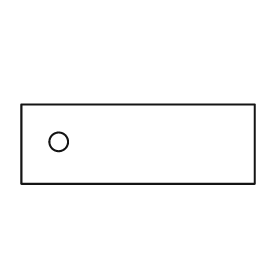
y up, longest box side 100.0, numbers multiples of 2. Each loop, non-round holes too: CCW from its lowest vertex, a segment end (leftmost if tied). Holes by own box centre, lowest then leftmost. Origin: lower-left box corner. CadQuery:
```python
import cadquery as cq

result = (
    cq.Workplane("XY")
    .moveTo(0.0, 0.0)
    .lineTo(100.0, 0.0)
    .lineTo(100.0, 34.0)
    .lineTo(0.0, 34.0)
    .close()
    .moveTo(16.0, 18.0)
    .circle(4.0)
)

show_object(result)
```